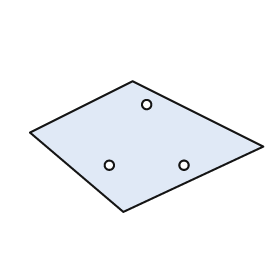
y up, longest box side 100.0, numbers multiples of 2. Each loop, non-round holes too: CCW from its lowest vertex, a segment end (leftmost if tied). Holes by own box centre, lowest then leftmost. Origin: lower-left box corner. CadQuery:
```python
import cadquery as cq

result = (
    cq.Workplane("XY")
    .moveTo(40.0, 0.0)
    .lineTo(100.0, 28.0)
    .lineTo(44.0, 56.0)
    .lineTo(0.0, 34.0)
    .close()
    .moveTo(34.0, 20.0)
    .circle(2.0)
    .moveTo(66.0, 20.0)
    .circle(2.0)
    .moveTo(50.0, 46.0)
    .circle(2.0)
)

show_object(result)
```